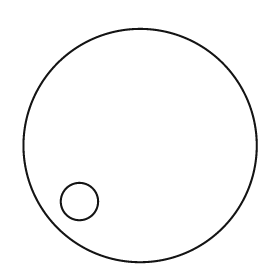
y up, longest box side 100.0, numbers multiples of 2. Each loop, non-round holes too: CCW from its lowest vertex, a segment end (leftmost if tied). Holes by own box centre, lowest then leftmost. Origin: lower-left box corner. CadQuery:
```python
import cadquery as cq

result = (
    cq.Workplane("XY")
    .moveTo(50.0, 50.0)
    .circle(50.0)
    .moveTo(24.0, 26.0)
    .circle(8.0)
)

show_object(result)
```